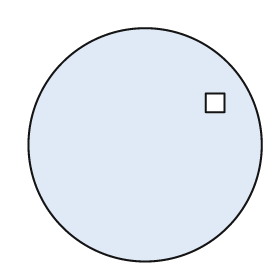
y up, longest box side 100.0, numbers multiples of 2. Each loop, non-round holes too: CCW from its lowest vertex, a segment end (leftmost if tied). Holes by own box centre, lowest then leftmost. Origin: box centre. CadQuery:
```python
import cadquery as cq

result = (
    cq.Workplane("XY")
    .moveTo(0.0, 0.0)
    .circle(50.0)
    .moveTo(26.0, 14.0)
    .lineTo(34.0, 14.0)
    .lineTo(34.0, 22.0)
    .lineTo(26.0, 22.0)
    .close()
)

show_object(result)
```